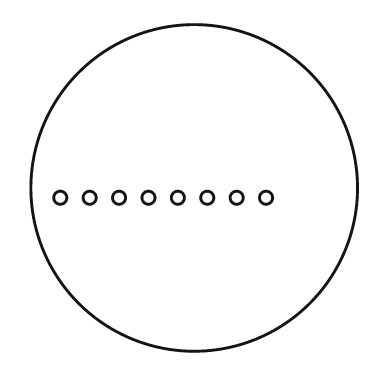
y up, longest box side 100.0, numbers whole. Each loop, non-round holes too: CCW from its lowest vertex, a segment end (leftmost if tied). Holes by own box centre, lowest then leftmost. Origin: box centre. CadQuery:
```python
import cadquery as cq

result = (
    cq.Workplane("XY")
    .moveTo(0.0, 0.0)
    .circle(50.0)
    .moveTo(-41.0, -3.0)
    .circle(2.0)
    .moveTo(-32.0, -3.0)
    .circle(2.0)
    .moveTo(-23.0, -3.0)
    .circle(2.0)
    .moveTo(-14.0, -3.0)
    .circle(2.0)
    .moveTo(-5.0, -3.0)
    .circle(2.0)
    .moveTo(4.0, -3.0)
    .circle(2.0)
    .moveTo(13.0, -3.0)
    .circle(2.0)
    .moveTo(22.0, -3.0)
    .circle(2.0)
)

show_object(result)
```